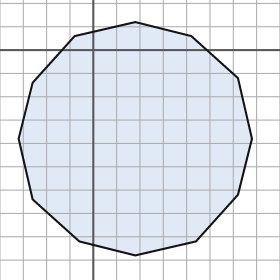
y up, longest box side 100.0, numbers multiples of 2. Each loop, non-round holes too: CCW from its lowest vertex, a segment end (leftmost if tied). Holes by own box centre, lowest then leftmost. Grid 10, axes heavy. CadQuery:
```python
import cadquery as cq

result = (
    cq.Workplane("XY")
    .moveTo(18.0, -88.0)
    .lineTo(44.0, -82.0)
    .lineTo(62.0, -62.0)
    .lineTo(68.0, -38.0)
    .lineTo(62.0, -12.0)
    .lineTo(42.0, 6.0)
    .lineTo(18.0, 12.0)
    .lineTo(-8.0, 6.0)
    .lineTo(-26.0, -14.0)
    .lineTo(-32.0, -38.0)
    .lineTo(-26.0, -64.0)
    .lineTo(-6.0, -82.0)
    .close()
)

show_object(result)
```